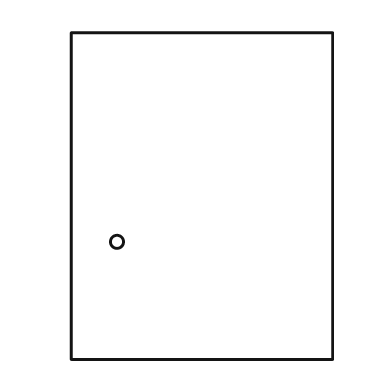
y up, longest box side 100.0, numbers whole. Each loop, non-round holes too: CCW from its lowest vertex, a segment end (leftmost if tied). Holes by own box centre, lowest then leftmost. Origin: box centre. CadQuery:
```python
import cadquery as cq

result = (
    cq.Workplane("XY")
    .moveTo(-40.0, -50.0)
    .lineTo(40.0, -50.0)
    .lineTo(40.0, 50.0)
    .lineTo(-40.0, 50.0)
    .close()
    .moveTo(-26.0, -14.0)
    .circle(2.0)
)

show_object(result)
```